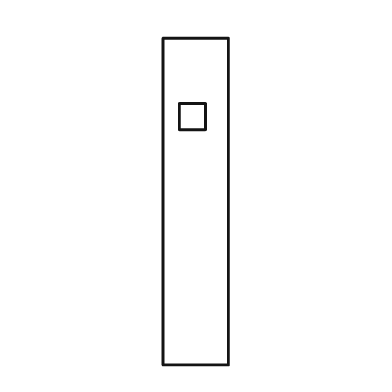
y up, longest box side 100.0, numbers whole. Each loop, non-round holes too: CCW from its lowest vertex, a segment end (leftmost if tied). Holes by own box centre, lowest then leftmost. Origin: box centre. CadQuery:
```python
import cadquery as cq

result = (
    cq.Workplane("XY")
    .moveTo(-10.0, -50.0)
    .lineTo(10.0, -50.0)
    .lineTo(10.0, 50.0)
    .lineTo(-10.0, 50.0)
    .close()
    .moveTo(-5.0, 22.0)
    .lineTo(3.0, 22.0)
    .lineTo(3.0, 30.0)
    .lineTo(-5.0, 30.0)
    .close()
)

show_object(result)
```